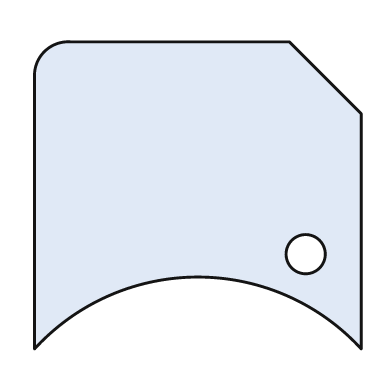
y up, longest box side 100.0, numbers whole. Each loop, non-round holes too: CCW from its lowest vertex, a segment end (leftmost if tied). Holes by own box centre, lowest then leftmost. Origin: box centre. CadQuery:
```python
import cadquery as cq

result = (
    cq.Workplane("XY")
    .moveTo(-50.0, -47.0)
    .threePointArc((0.0, -25.0), (50.0, -47.0))
    .lineTo(50.0, 25.0)
    .lineTo(28.0, 47.0)
    .lineTo(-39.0, 47.0)
    .threePointArc((-47.0, 44.0), (-50.0, 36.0))
    .close()
    .moveTo(33.0, -18.0)
    .circle(6.0)
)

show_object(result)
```